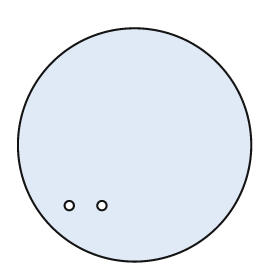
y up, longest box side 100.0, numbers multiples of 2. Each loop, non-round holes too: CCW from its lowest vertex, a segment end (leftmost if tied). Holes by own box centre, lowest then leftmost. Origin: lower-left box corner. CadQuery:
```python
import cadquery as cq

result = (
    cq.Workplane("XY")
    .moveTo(50.0, 50.0)
    .circle(50.0)
    .moveTo(22.0, 24.0)
    .circle(2.0)
    .moveTo(36.0, 24.0)
    .circle(2.0)
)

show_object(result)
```